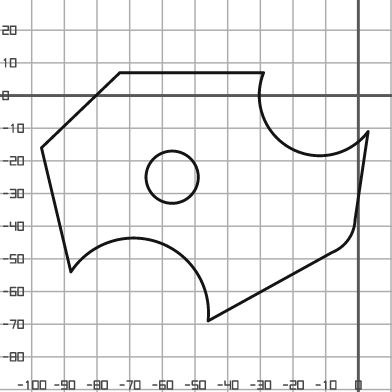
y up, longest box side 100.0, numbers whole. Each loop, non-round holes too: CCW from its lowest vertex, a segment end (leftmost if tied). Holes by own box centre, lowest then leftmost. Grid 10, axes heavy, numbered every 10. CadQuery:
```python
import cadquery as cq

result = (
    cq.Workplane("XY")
    .moveTo(-46.0, -69.0)
    .lineTo(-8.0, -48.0)
    .threePointArc((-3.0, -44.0), (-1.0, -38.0))
    .lineTo(3.0, -11.0)
    .threePointArc((-21.0, -16.0), (-29.0, 7.0))
    .lineTo(-73.0, 7.0)
    .lineTo(-97.0, -16.0)
    .lineTo(-88.0, -54.0)
    .threePointArc((-61.0, -45.0), (-46.0, -69.0))
    .close()
    .moveTo(-57.0, -25.0)
    .circle(8.0)
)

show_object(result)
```